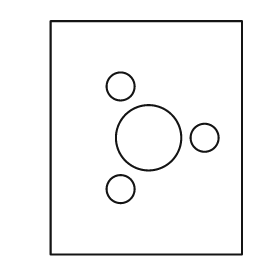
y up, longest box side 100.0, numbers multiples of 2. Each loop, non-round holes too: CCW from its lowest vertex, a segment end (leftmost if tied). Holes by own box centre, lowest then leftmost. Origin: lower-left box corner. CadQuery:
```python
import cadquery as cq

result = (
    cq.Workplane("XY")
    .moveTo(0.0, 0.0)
    .lineTo(82.0, 0.0)
    .lineTo(82.0, 100.0)
    .lineTo(0.0, 100.0)
    .close()
    .moveTo(30.0, 28.0)
    .circle(6.0)
    .moveTo(42.0, 50.0)
    .circle(14.0)
    .moveTo(66.0, 50.0)
    .circle(6.0)
    .moveTo(30.0, 72.0)
    .circle(6.0)
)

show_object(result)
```